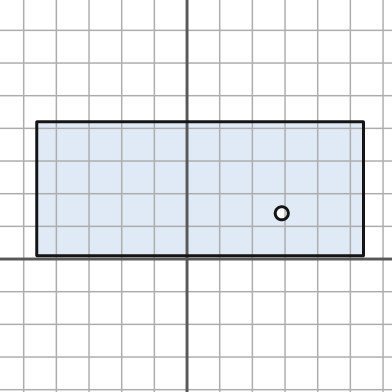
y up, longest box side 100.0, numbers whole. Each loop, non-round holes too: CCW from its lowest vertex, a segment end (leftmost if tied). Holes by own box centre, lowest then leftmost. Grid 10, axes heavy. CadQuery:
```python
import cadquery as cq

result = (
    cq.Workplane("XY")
    .moveTo(-46.0, 1.0)
    .lineTo(54.0, 1.0)
    .lineTo(54.0, 42.0)
    .lineTo(-46.0, 42.0)
    .close()
    .moveTo(29.0, 14.0)
    .circle(2.0)
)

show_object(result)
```